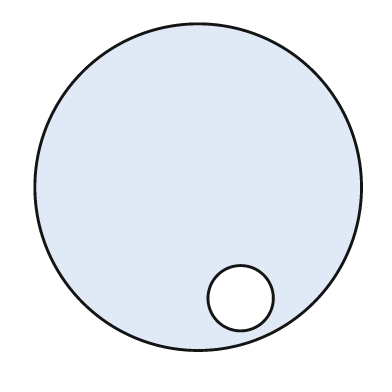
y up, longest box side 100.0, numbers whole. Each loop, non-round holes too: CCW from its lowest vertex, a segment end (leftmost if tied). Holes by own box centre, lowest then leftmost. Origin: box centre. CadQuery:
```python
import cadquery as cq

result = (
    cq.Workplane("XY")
    .moveTo(0.0, 0.0)
    .circle(50.0)
    .moveTo(13.0, -34.0)
    .circle(10.0)
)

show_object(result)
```